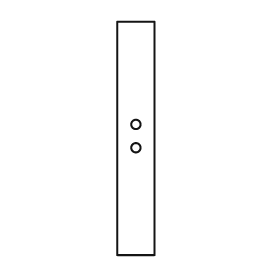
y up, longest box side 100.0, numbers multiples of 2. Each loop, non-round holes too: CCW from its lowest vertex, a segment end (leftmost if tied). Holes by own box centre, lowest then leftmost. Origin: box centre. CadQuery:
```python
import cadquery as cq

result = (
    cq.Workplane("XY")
    .moveTo(-8.0, -50.0)
    .lineTo(8.0, -50.0)
    .lineTo(8.0, 50.0)
    .lineTo(-8.0, 50.0)
    .close()
    .moveTo(0.0, -4.0)
    .circle(2.0)
    .moveTo(0.0, 6.0)
    .circle(2.0)
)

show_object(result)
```